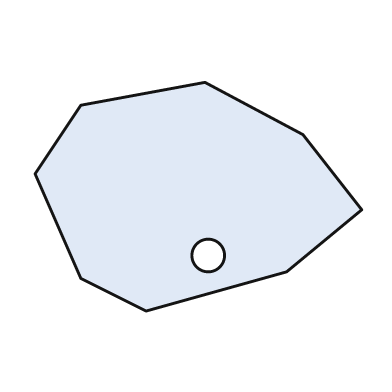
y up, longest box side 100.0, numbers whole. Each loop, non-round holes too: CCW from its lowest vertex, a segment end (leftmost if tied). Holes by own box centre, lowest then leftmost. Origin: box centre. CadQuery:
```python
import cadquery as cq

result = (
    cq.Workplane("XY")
    .moveTo(-16.0, -35.0)
    .lineTo(27.0, -23.0)
    .lineTo(50.0, -4.0)
    .lineTo(32.0, 19.0)
    .lineTo(2.0, 35.0)
    .lineTo(-36.0, 28.0)
    .lineTo(-50.0, 7.0)
    .lineTo(-36.0, -25.0)
    .close()
    .moveTo(3.0, -18.0)
    .circle(5.0)
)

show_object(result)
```